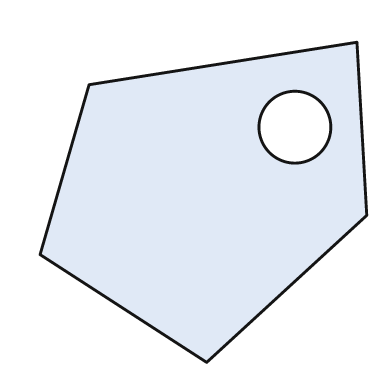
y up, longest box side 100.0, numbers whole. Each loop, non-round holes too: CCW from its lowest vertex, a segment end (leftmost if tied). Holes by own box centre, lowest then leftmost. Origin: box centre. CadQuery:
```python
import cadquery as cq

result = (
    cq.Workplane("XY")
    .moveTo(1.0, -49.0)
    .lineTo(50.0, -4.0)
    .lineTo(47.0, 49.0)
    .lineTo(-35.0, 36.0)
    .lineTo(-50.0, -16.0)
    .close()
    .moveTo(28.0, 23.0)
    .circle(11.0)
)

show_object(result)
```